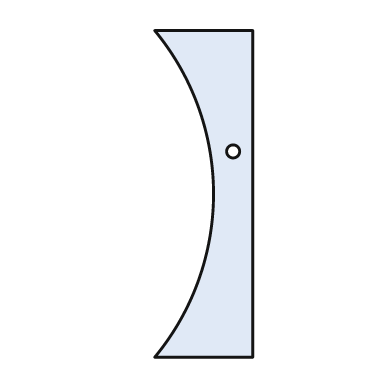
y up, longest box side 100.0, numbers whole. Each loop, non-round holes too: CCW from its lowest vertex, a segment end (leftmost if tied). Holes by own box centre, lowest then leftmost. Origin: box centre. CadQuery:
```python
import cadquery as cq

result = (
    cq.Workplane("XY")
    .moveTo(-15.0, -50.0)
    .lineTo(15.0, -50.0)
    .lineTo(15.0, 50.0)
    .lineTo(-15.0, 50.0)
    .threePointArc((3.0, 0.0), (-15.0, -50.0))
    .close()
    .moveTo(9.0, 13.0)
    .circle(2.0)
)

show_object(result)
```